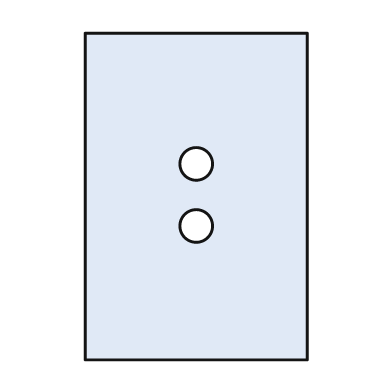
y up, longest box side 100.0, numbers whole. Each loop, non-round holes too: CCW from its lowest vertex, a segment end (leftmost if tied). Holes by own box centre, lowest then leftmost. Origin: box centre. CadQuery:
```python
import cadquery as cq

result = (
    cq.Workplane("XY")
    .moveTo(-34.0, -50.0)
    .lineTo(34.0, -50.0)
    .lineTo(34.0, 50.0)
    .lineTo(-34.0, 50.0)
    .close()
    .moveTo(0.0, -9.0)
    .circle(5.0)
    .moveTo(0.0, 10.0)
    .circle(5.0)
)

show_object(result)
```